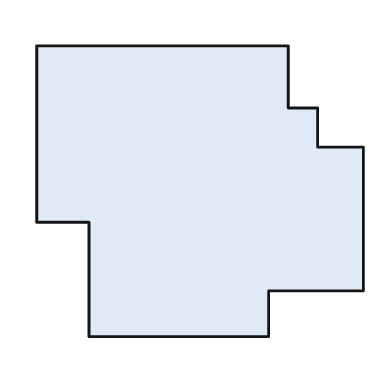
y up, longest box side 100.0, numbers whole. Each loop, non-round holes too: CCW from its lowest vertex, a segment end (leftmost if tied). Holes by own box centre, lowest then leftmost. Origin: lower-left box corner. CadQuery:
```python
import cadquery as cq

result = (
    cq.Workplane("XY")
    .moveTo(16.0, 0.0)
    .lineTo(71.0, 0.0)
    .lineTo(71.0, 14.0)
    .lineTo(100.0, 14.0)
    .lineTo(100.0, 58.0)
    .lineTo(86.0, 58.0)
    .lineTo(86.0, 70.0)
    .lineTo(77.0, 70.0)
    .lineTo(77.0, 89.0)
    .lineTo(0.0, 89.0)
    .lineTo(0.0, 35.0)
    .lineTo(16.0, 35.0)
    .close()
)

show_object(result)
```